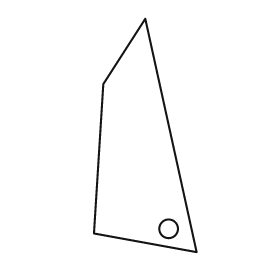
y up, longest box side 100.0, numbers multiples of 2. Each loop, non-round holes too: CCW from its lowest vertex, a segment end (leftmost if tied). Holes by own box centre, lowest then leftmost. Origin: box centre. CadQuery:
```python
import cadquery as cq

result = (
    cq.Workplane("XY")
    .moveTo(22.0, -50.0)
    .lineTo(0.0, 50.0)
    .lineTo(-18.0, 22.0)
    .lineTo(-22.0, -42.0)
    .close()
    .moveTo(10.0, -40.0)
    .circle(4.0)
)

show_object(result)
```